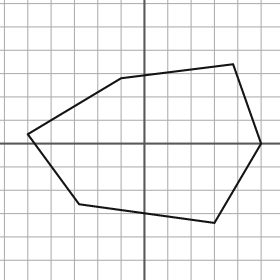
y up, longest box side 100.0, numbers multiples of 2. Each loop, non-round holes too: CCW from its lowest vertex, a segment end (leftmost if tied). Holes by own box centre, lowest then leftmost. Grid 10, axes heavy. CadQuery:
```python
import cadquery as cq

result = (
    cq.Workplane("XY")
    .moveTo(30.0, -34.0)
    .lineTo(50.0, 0.0)
    .lineTo(38.0, 34.0)
    .lineTo(-10.0, 28.0)
    .lineTo(-50.0, 4.0)
    .lineTo(-28.0, -26.0)
    .close()
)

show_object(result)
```